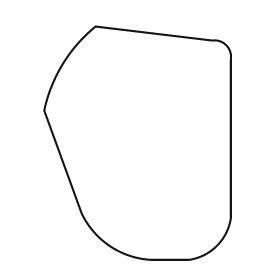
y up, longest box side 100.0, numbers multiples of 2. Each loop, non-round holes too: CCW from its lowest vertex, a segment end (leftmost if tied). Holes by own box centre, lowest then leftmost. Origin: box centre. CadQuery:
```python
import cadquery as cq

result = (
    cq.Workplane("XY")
    .moveTo(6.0, -50.0)
    .lineTo(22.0, -50.0)
    .threePointArc((34.0, -44.0), (40.0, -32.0))
    .lineTo(40.0, 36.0)
    .threePointArc((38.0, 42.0), (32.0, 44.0))
    .lineTo(-18.0, 50.0)
    .threePointArc((-32.0, 34.0), (-40.0, 14.0))
    .lineTo(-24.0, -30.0)
    .threePointArc((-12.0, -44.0), (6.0, -50.0))
    .close()
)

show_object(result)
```